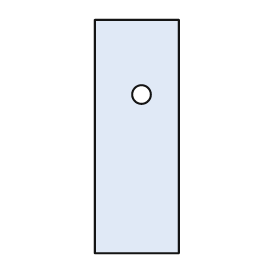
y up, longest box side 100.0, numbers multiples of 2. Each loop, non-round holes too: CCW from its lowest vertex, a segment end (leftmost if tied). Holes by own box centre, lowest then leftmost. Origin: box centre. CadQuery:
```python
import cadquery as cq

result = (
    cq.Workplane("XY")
    .moveTo(-18.0, -50.0)
    .lineTo(18.0, -50.0)
    .lineTo(18.0, 50.0)
    .lineTo(-18.0, 50.0)
    .close()
    .moveTo(2.0, 18.0)
    .circle(4.0)
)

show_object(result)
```